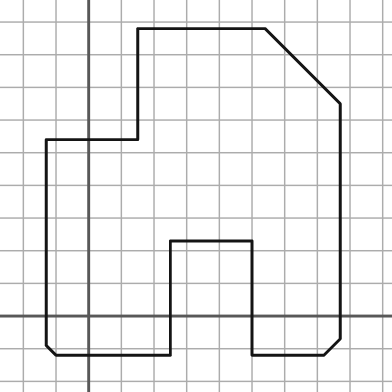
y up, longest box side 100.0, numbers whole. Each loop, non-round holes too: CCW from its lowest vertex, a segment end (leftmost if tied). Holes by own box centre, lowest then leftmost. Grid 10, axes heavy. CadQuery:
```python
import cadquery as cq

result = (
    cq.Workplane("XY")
    .moveTo(-10.0, -12.0)
    .lineTo(25.0, -12.0)
    .lineTo(25.0, 23.0)
    .lineTo(50.0, 23.0)
    .lineTo(50.0, -12.0)
    .lineTo(72.0, -12.0)
    .lineTo(77.0, -7.0)
    .lineTo(77.0, 65.0)
    .lineTo(54.0, 88.0)
    .lineTo(15.0, 88.0)
    .lineTo(15.0, 54.0)
    .lineTo(-13.0, 54.0)
    .lineTo(-13.0, -9.0)
    .close()
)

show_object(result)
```